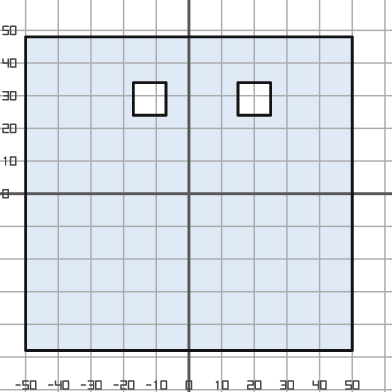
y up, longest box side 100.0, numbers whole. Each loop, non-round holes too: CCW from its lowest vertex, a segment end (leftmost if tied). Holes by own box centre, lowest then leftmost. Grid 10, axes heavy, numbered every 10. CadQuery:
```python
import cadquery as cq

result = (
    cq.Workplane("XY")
    .moveTo(-50.0, -48.0)
    .lineTo(50.0, -48.0)
    .lineTo(50.0, 48.0)
    .lineTo(-50.0, 48.0)
    .close()
    .moveTo(-17.0, 24.0)
    .lineTo(-7.0, 24.0)
    .lineTo(-7.0, 34.0)
    .lineTo(-17.0, 34.0)
    .close()
    .moveTo(15.0, 24.0)
    .lineTo(25.0, 24.0)
    .lineTo(25.0, 34.0)
    .lineTo(15.0, 34.0)
    .close()
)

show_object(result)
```